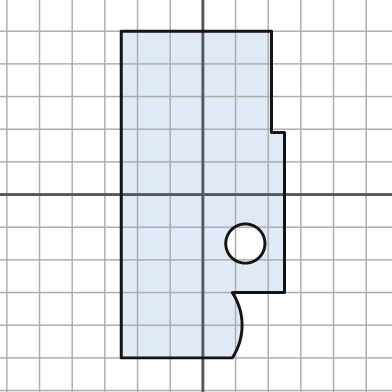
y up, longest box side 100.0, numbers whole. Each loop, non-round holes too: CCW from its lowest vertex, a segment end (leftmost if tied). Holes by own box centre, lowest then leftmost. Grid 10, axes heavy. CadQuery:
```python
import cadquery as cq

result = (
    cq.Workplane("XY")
    .moveTo(-25.0, -50.0)
    .lineTo(9.0, -50.0)
    .threePointArc((12.0, -40.0), (9.0, -30.0))
    .lineTo(25.0, -30.0)
    .lineTo(25.0, 19.0)
    .lineTo(21.0, 19.0)
    .lineTo(21.0, 50.0)
    .lineTo(-25.0, 50.0)
    .close()
    .moveTo(13.0, -15.0)
    .circle(6.0)
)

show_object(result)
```